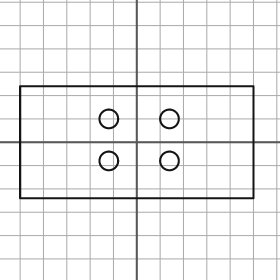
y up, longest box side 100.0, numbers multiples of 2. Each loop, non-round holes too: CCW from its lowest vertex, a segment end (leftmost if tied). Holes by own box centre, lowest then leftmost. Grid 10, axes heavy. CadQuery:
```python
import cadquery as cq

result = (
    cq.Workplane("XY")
    .moveTo(-50.0, -24.0)
    .lineTo(50.0, -24.0)
    .lineTo(50.0, 24.0)
    .lineTo(-50.0, 24.0)
    .close()
    .moveTo(-12.0, -8.0)
    .circle(4.0)
    .moveTo(14.0, -8.0)
    .circle(4.0)
    .moveTo(-12.0, 10.0)
    .circle(4.0)
    .moveTo(14.0, 10.0)
    .circle(4.0)
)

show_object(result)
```